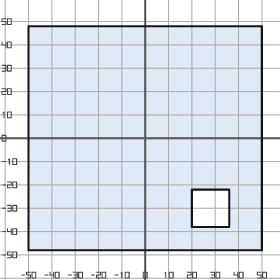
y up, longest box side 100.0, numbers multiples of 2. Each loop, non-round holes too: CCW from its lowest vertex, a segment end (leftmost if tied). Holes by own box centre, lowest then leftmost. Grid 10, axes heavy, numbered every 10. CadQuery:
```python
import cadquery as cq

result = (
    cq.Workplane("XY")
    .moveTo(-50.0, -48.0)
    .lineTo(50.0, -48.0)
    .lineTo(50.0, 48.0)
    .lineTo(-50.0, 48.0)
    .close()
    .moveTo(20.0, -38.0)
    .lineTo(36.0, -38.0)
    .lineTo(36.0, -22.0)
    .lineTo(20.0, -22.0)
    .close()
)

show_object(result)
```